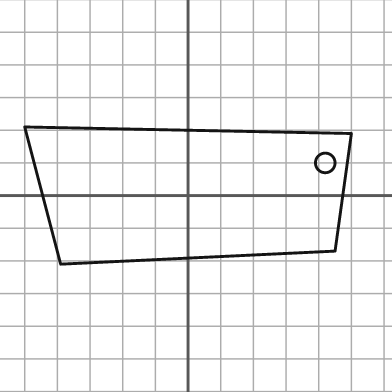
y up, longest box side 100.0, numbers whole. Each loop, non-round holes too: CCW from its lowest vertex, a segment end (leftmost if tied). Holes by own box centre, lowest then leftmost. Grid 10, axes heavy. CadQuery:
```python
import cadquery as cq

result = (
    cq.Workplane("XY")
    .moveTo(-39.0, -21.0)
    .lineTo(45.0, -17.0)
    .lineTo(50.0, 19.0)
    .lineTo(-50.0, 21.0)
    .close()
    .moveTo(42.0, 10.0)
    .circle(3.0)
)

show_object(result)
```